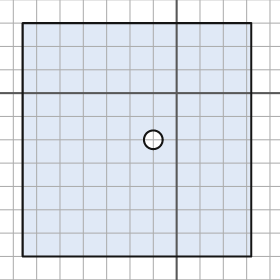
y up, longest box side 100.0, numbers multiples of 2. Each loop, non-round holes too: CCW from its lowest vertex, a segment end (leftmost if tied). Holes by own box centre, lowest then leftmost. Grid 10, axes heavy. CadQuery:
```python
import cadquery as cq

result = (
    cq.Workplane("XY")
    .moveTo(-66.0, -70.0)
    .lineTo(32.0, -70.0)
    .lineTo(32.0, 30.0)
    .lineTo(-66.0, 30.0)
    .close()
    .moveTo(-10.0, -20.0)
    .circle(4.0)
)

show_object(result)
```